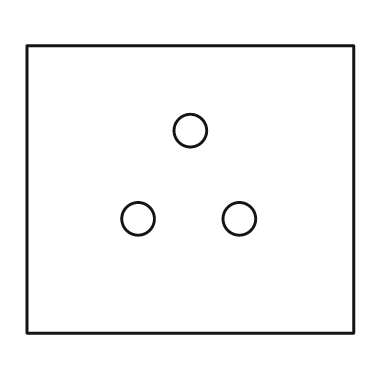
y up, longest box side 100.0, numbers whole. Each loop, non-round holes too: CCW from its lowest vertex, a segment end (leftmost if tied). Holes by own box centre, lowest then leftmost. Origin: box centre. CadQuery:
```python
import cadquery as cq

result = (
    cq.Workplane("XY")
    .moveTo(-50.0, -44.0)
    .lineTo(50.0, -44.0)
    .lineTo(50.0, 44.0)
    .lineTo(-50.0, 44.0)
    .close()
    .moveTo(-16.0, -9.0)
    .circle(5.0)
    .moveTo(15.0, -9.0)
    .circle(5.0)
    .moveTo(0.0, 18.0)
    .circle(5.0)
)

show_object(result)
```